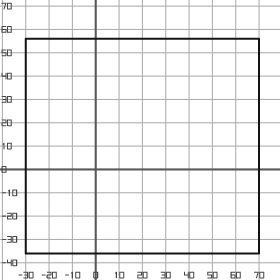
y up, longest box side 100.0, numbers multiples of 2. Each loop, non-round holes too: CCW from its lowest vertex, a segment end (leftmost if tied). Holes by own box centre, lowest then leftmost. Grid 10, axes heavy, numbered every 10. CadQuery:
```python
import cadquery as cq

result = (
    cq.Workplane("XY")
    .moveTo(-30.0, -36.0)
    .lineTo(70.0, -36.0)
    .lineTo(70.0, 56.0)
    .lineTo(-30.0, 56.0)
    .close()
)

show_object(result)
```